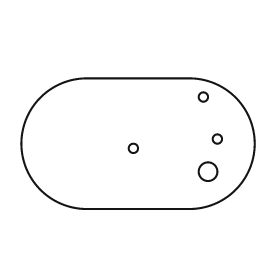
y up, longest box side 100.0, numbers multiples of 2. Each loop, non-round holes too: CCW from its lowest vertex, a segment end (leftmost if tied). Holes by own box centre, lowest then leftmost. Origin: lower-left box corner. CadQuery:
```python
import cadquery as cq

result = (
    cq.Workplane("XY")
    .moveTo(28.0, 0.0)
    .lineTo(72.0, 0.0)
    .threePointArc((100.0, 28.0), (72.0, 56.0))
    .lineTo(28.0, 56.0)
    .threePointArc((0.0, 28.0), (28.0, 0.0))
    .close()
    .moveTo(80.0, 16.0)
    .circle(4.0)
    .moveTo(48.0, 26.0)
    .circle(2.0)
    .moveTo(84.0, 30.0)
    .circle(2.0)
    .moveTo(78.0, 48.0)
    .circle(2.0)
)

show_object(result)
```